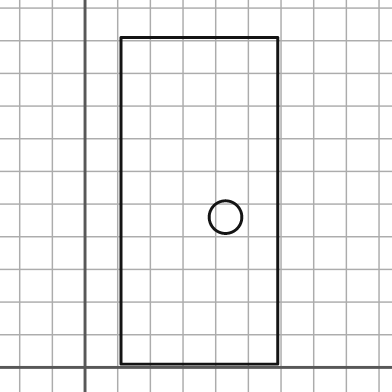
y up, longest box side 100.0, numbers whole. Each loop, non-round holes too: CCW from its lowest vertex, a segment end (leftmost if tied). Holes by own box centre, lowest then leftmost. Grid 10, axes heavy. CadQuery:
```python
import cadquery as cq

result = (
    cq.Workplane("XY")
    .moveTo(11.0, 1.0)
    .lineTo(59.0, 1.0)
    .lineTo(59.0, 101.0)
    .lineTo(11.0, 101.0)
    .close()
    .moveTo(43.0, 46.0)
    .circle(5.0)
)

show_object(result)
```